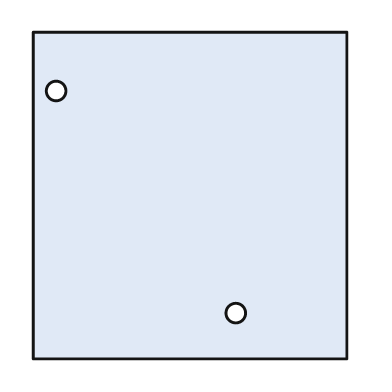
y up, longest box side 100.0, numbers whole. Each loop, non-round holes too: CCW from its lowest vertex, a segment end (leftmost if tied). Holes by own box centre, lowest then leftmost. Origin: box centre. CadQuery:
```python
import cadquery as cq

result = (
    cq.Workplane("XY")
    .moveTo(-48.0, -50.0)
    .lineTo(48.0, -50.0)
    .lineTo(48.0, 50.0)
    .lineTo(-48.0, 50.0)
    .close()
    .moveTo(14.0, -36.0)
    .circle(3.0)
    .moveTo(-41.0, 32.0)
    .circle(3.0)
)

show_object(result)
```